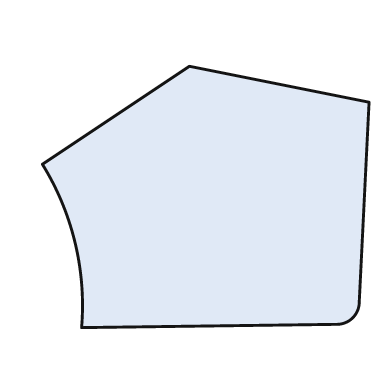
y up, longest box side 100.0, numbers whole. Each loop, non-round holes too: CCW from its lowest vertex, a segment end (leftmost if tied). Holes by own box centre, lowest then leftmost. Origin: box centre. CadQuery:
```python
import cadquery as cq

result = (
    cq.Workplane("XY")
    .moveTo(-38.0, -40.0)
    .lineTo(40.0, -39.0)
    .threePointArc((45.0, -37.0), (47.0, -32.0))
    .lineTo(50.0, 29.0)
    .lineTo(-5.0, 40.0)
    .lineTo(-50.0, 10.0)
    .threePointArc((-40.0, -14.0), (-38.0, -40.0))
    .close()
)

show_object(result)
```